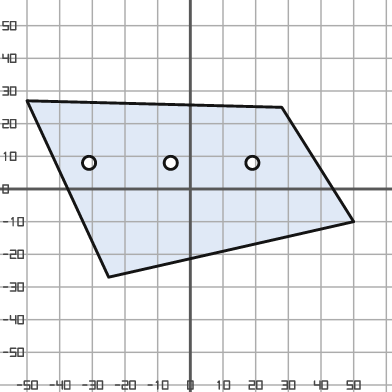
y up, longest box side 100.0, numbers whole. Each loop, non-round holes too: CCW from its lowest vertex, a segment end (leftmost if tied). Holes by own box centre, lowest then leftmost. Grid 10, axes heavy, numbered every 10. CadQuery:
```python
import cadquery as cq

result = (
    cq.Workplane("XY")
    .moveTo(-25.0, -27.0)
    .lineTo(50.0, -10.0)
    .lineTo(28.0, 25.0)
    .lineTo(-50.0, 27.0)
    .close()
    .moveTo(-31.0, 8.0)
    .circle(2.0)
    .moveTo(-6.0, 8.0)
    .circle(2.0)
    .moveTo(19.0, 8.0)
    .circle(2.0)
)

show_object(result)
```